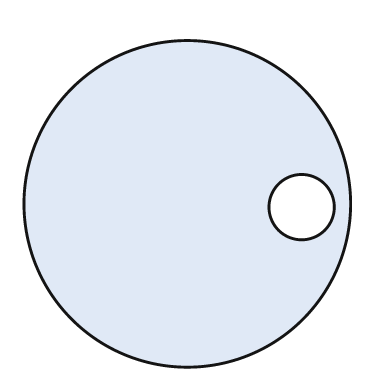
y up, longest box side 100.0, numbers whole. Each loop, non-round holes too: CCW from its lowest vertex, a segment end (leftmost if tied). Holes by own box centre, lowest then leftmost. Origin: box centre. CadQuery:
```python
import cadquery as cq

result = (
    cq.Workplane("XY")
    .moveTo(0.0, 0.0)
    .circle(50.0)
    .moveTo(35.0, -1.0)
    .circle(10.0)
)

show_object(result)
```